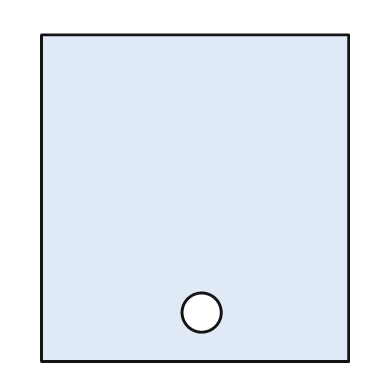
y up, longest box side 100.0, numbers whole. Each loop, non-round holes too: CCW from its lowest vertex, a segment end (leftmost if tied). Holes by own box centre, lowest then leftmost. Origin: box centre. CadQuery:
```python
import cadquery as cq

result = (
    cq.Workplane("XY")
    .moveTo(-47.0, -50.0)
    .lineTo(47.0, -50.0)
    .lineTo(47.0, 50.0)
    .lineTo(-47.0, 50.0)
    .close()
    .moveTo(2.0, -35.0)
    .circle(6.0)
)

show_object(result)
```